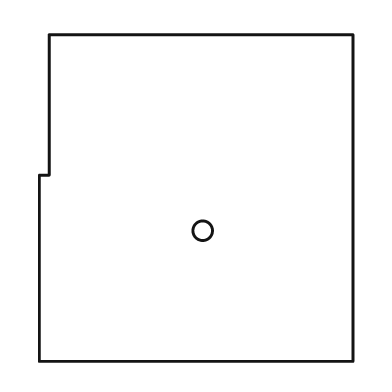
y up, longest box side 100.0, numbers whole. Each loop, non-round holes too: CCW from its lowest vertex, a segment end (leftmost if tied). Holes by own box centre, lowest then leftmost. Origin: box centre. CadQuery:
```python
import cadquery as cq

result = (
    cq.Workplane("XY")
    .moveTo(-48.0, -50.0)
    .lineTo(48.0, -50.0)
    .lineTo(48.0, 50.0)
    .lineTo(-45.0, 50.0)
    .lineTo(-45.0, 7.0)
    .lineTo(-48.0, 7.0)
    .close()
    .moveTo(2.0, -10.0)
    .circle(3.0)
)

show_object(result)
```